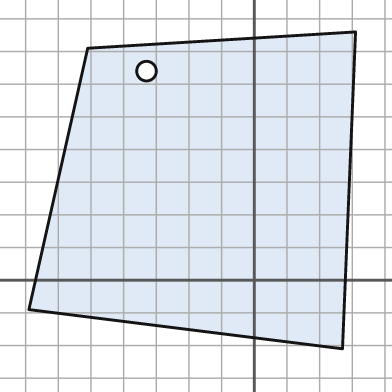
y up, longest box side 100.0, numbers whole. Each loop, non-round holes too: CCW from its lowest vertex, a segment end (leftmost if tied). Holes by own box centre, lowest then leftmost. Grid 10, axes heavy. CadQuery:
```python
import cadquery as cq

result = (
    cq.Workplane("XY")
    .moveTo(27.0, -21.0)
    .lineTo(31.0, 76.0)
    .lineTo(-51.0, 71.0)
    .lineTo(-69.0, -9.0)
    .close()
    .moveTo(-33.0, 64.0)
    .circle(3.0)
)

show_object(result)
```